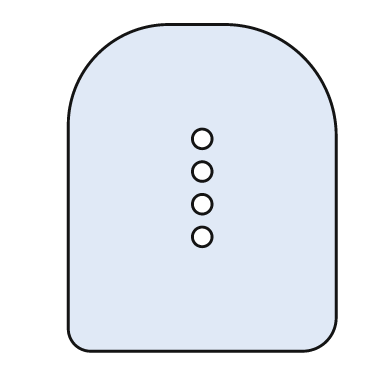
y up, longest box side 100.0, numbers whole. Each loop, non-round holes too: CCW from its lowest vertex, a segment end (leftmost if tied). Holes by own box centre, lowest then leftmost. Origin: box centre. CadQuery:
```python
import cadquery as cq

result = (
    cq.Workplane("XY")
    .moveTo(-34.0, -50.0)
    .lineTo(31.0, -50.0)
    .threePointArc((38.0, -47.0), (41.0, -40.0))
    .lineTo(41.0, 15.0)
    .threePointArc((31.0, 40.0), (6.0, 50.0))
    .lineTo(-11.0, 50.0)
    .threePointArc((-32.0, 41.0), (-41.0, 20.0))
    .lineTo(-41.0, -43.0)
    .threePointArc((-39.0, -48.0), (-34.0, -50.0))
    .close()
    .moveTo(0.0, -15.0)
    .circle(3.0)
    .moveTo(0.0, -5.0)
    .circle(3.0)
    .moveTo(0.0, 5.0)
    .circle(3.0)
    .moveTo(0.0, 15.0)
    .circle(3.0)
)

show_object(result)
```